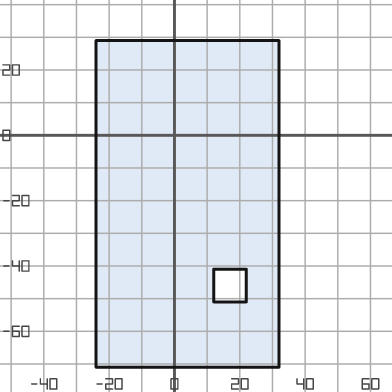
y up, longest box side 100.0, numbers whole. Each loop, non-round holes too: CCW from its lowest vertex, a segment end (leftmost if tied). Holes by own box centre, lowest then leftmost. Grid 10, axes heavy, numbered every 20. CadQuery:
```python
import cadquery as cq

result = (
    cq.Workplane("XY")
    .moveTo(-24.0, -71.0)
    .lineTo(32.0, -71.0)
    .lineTo(32.0, 29.0)
    .lineTo(-24.0, 29.0)
    .close()
    .moveTo(12.0, -51.0)
    .lineTo(22.0, -51.0)
    .lineTo(22.0, -41.0)
    .lineTo(12.0, -41.0)
    .close()
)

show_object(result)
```